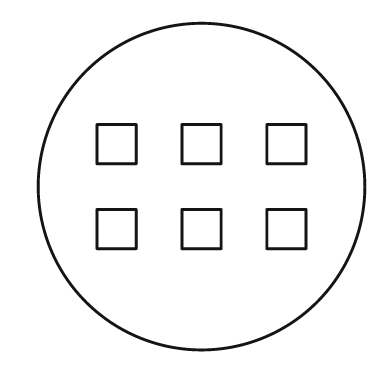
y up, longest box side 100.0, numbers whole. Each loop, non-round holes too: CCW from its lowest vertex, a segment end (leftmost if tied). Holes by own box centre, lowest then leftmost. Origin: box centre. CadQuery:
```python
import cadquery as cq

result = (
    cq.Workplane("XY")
    .moveTo(0.0, 0.0)
    .circle(50.0)
    .moveTo(-32.0, -19.0)
    .lineTo(-20.0, -19.0)
    .lineTo(-20.0, -7.0)
    .lineTo(-32.0, -7.0)
    .close()
    .moveTo(-6.0, -19.0)
    .lineTo(6.0, -19.0)
    .lineTo(6.0, -7.0)
    .lineTo(-6.0, -7.0)
    .close()
    .moveTo(20.0, -19.0)
    .lineTo(32.0, -19.0)
    .lineTo(32.0, -7.0)
    .lineTo(20.0, -7.0)
    .close()
    .moveTo(-32.0, 7.0)
    .lineTo(-20.0, 7.0)
    .lineTo(-20.0, 19.0)
    .lineTo(-32.0, 19.0)
    .close()
    .moveTo(-6.0, 7.0)
    .lineTo(6.0, 7.0)
    .lineTo(6.0, 19.0)
    .lineTo(-6.0, 19.0)
    .close()
    .moveTo(20.0, 7.0)
    .lineTo(32.0, 7.0)
    .lineTo(32.0, 19.0)
    .lineTo(20.0, 19.0)
    .close()
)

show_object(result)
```